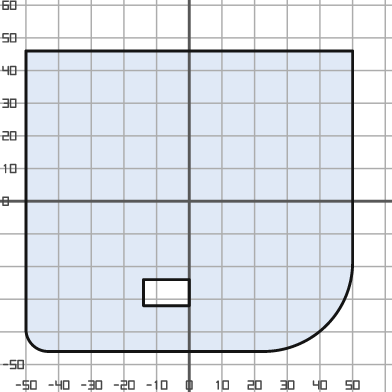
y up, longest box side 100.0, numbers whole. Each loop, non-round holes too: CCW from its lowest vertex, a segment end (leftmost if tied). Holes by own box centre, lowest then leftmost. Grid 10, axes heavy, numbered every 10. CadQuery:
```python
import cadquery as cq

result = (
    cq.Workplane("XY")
    .moveTo(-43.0, -46.0)
    .lineTo(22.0, -46.0)
    .threePointArc((42.0, -38.0), (50.0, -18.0))
    .lineTo(50.0, 46.0)
    .lineTo(-50.0, 46.0)
    .lineTo(-50.0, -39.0)
    .threePointArc((-48.0, -44.0), (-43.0, -46.0))
    .close()
    .moveTo(-14.0, -32.0)
    .lineTo(0.0, -32.0)
    .lineTo(0.0, -24.0)
    .lineTo(-14.0, -24.0)
    .close()
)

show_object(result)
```